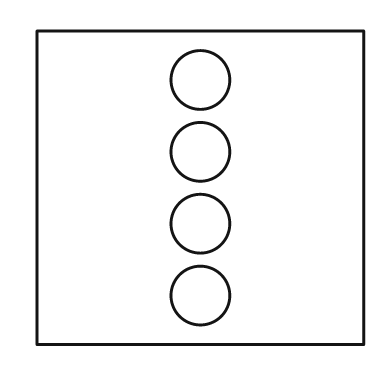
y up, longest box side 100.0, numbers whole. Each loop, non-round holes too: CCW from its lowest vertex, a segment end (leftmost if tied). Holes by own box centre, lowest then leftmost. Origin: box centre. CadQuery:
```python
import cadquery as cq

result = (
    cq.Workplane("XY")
    .moveTo(-50.0, -48.0)
    .lineTo(50.0, -48.0)
    .lineTo(50.0, 48.0)
    .lineTo(-50.0, 48.0)
    .close()
    .moveTo(0.0, -33.0)
    .circle(9.0)
    .moveTo(0.0, -11.0)
    .circle(9.0)
    .moveTo(0.0, 11.0)
    .circle(9.0)
    .moveTo(0.0, 33.0)
    .circle(9.0)
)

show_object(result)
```